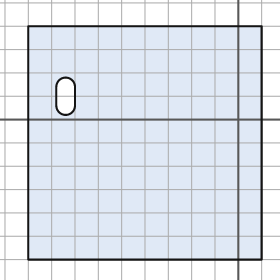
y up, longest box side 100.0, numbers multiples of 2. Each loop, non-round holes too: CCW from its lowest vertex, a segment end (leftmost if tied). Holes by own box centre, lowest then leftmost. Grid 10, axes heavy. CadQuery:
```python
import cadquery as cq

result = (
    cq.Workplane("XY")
    .moveTo(-90.0, -60.0)
    .lineTo(10.0, -60.0)
    .lineTo(10.0, 40.0)
    .lineTo(-90.0, 40.0)
    .close()
    .moveTo(-78.0, 6.0)
    .threePointArc((-74.0, 2.0), (-70.0, 6.0))
    .lineTo(-70.0, 14.0)
    .threePointArc((-74.0, 18.0), (-78.0, 14.0))
    .close()
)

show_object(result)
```